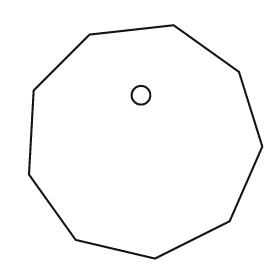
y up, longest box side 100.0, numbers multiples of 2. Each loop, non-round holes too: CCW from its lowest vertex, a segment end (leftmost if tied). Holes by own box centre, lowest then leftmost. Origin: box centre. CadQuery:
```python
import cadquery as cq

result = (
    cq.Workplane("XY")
    .moveTo(4.0, -50.0)
    .lineTo(36.0, -34.0)
    .lineTo(50.0, -2.0)
    .lineTo(40.0, 30.0)
    .lineTo(12.0, 50.0)
    .lineTo(-24.0, 46.0)
    .lineTo(-48.0, 22.0)
    .lineTo(-50.0, -14.0)
    .lineTo(-30.0, -42.0)
    .close()
    .moveTo(-2.0, 20.0)
    .circle(4.0)
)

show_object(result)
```